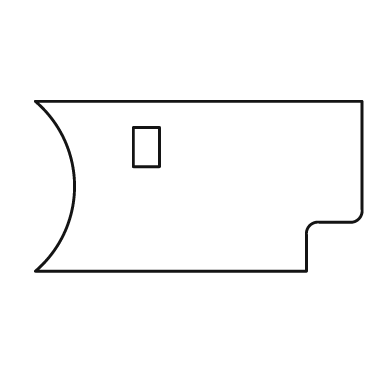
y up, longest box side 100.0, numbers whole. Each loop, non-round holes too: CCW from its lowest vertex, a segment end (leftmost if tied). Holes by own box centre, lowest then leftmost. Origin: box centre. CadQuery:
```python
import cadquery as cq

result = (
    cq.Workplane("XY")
    .moveTo(-50.0, -26.0)
    .lineTo(33.0, -26.0)
    .lineTo(33.0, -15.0)
    .threePointArc((34.0, -12.0), (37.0, -11.0))
    .lineTo(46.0, -11.0)
    .threePointArc((49.0, -10.0), (50.0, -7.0))
    .lineTo(50.0, 26.0)
    .lineTo(-50.0, 26.0)
    .threePointArc((-38.0, 0.0), (-50.0, -26.0))
    .close()
    .moveTo(-20.0, 6.0)
    .lineTo(-12.0, 6.0)
    .lineTo(-12.0, 18.0)
    .lineTo(-20.0, 18.0)
    .close()
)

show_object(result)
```